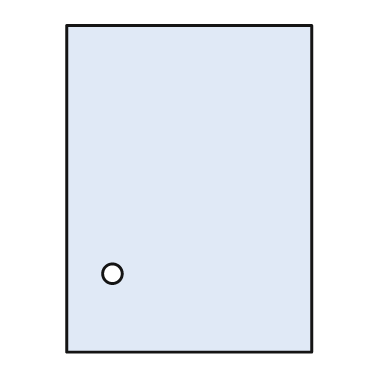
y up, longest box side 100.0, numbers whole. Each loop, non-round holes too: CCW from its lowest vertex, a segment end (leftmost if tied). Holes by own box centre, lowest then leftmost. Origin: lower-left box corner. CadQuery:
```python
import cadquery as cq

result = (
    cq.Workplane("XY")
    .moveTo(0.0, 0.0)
    .lineTo(75.0, 0.0)
    .lineTo(75.0, 100.0)
    .lineTo(0.0, 100.0)
    .close()
    .moveTo(14.0, 24.0)
    .circle(3.0)
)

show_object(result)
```